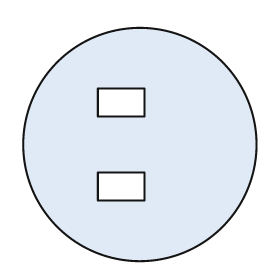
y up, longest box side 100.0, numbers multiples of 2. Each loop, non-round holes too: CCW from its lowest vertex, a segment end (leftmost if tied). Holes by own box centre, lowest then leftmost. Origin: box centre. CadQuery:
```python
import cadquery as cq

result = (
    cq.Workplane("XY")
    .moveTo(0.0, 0.0)
    .circle(50.0)
    .moveTo(-18.0, -24.0)
    .lineTo(2.0, -24.0)
    .lineTo(2.0, -12.0)
    .lineTo(-18.0, -12.0)
    .close()
    .moveTo(-18.0, 12.0)
    .lineTo(2.0, 12.0)
    .lineTo(2.0, 24.0)
    .lineTo(-18.0, 24.0)
    .close()
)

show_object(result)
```